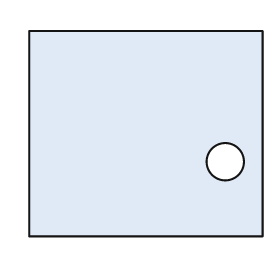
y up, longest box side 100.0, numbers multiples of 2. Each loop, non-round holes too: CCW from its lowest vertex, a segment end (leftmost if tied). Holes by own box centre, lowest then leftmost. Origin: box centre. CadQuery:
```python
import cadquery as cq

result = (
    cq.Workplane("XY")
    .moveTo(-50.0, -44.0)
    .lineTo(50.0, -44.0)
    .lineTo(50.0, 44.0)
    .lineTo(-50.0, 44.0)
    .close()
    .moveTo(34.0, -12.0)
    .circle(8.0)
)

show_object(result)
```